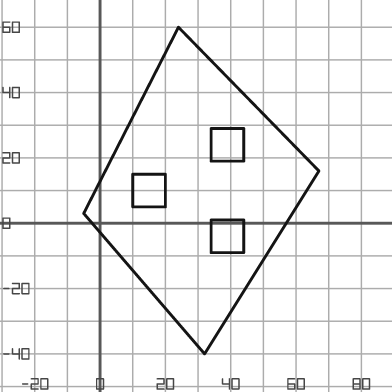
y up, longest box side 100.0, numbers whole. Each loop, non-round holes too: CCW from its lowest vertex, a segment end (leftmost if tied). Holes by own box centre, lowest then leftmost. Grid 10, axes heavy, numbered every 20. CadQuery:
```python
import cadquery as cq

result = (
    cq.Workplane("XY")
    .moveTo(32.0, -40.0)
    .lineTo(67.0, 16.0)
    .lineTo(24.0, 60.0)
    .lineTo(-5.0, 3.0)
    .close()
    .moveTo(34.0, -9.0)
    .lineTo(44.0, -9.0)
    .lineTo(44.0, 1.0)
    .lineTo(34.0, 1.0)
    .close()
    .moveTo(10.0, 5.0)
    .lineTo(20.0, 5.0)
    .lineTo(20.0, 15.0)
    .lineTo(10.0, 15.0)
    .close()
    .moveTo(34.0, 19.0)
    .lineTo(44.0, 19.0)
    .lineTo(44.0, 29.0)
    .lineTo(34.0, 29.0)
    .close()
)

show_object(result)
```